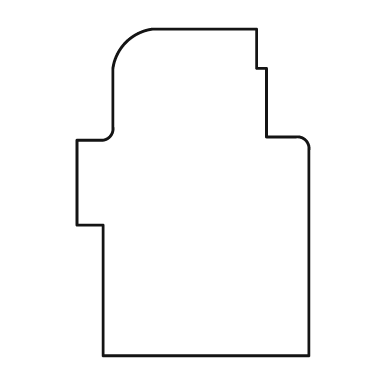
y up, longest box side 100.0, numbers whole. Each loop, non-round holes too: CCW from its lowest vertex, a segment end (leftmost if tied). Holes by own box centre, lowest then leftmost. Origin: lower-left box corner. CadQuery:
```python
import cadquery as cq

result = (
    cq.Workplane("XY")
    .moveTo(8.0, 0.0)
    .lineTo(71.0, 0.0)
    .lineTo(71.0, 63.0)
    .threePointArc((70.0, 66.0), (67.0, 67.0))
    .lineTo(58.0, 67.0)
    .lineTo(58.0, 88.0)
    .lineTo(55.0, 88.0)
    .lineTo(55.0, 100.0)
    .lineTo(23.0, 100.0)
    .threePointArc((15.0, 96.0), (11.0, 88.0))
    .lineTo(11.0, 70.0)
    .threePointArc((10.0, 67.0), (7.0, 66.0))
    .lineTo(0.0, 66.0)
    .lineTo(0.0, 40.0)
    .lineTo(8.0, 40.0)
    .close()
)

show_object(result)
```